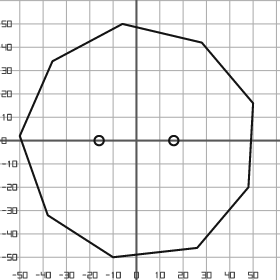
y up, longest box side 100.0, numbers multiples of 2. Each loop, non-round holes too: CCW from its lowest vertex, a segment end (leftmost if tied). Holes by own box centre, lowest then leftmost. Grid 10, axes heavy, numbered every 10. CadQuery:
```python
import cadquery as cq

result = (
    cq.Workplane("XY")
    .moveTo(-10.0, -50.0)
    .lineTo(26.0, -46.0)
    .lineTo(48.0, -20.0)
    .lineTo(50.0, 16.0)
    .lineTo(28.0, 42.0)
    .lineTo(-6.0, 50.0)
    .lineTo(-36.0, 34.0)
    .lineTo(-50.0, 2.0)
    .lineTo(-38.0, -32.0)
    .close()
    .moveTo(-16.0, 0.0)
    .circle(2.0)
    .moveTo(16.0, 0.0)
    .circle(2.0)
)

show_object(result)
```